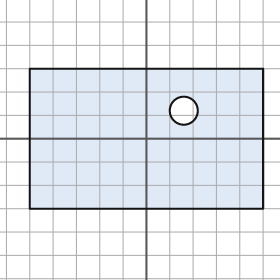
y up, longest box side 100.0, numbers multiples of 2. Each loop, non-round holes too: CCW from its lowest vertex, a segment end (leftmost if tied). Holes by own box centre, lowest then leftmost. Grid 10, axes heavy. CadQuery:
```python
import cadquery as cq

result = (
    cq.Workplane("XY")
    .moveTo(-50.0, -30.0)
    .lineTo(50.0, -30.0)
    .lineTo(50.0, 30.0)
    .lineTo(-50.0, 30.0)
    .close()
    .moveTo(16.0, 12.0)
    .circle(6.0)
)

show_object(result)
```